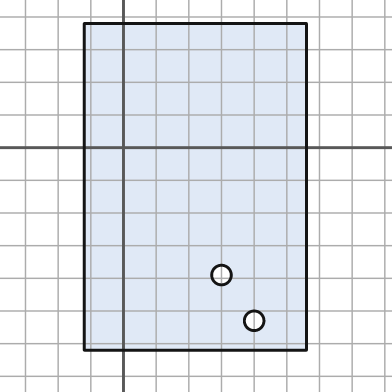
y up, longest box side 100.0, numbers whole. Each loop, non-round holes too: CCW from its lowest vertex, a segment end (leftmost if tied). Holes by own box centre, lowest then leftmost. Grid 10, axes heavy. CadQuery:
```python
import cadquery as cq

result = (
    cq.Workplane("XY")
    .moveTo(-12.0, -62.0)
    .lineTo(56.0, -62.0)
    .lineTo(56.0, 38.0)
    .lineTo(-12.0, 38.0)
    .close()
    .moveTo(40.0, -53.0)
    .circle(3.0)
    .moveTo(30.0, -39.0)
    .circle(3.0)
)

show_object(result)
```